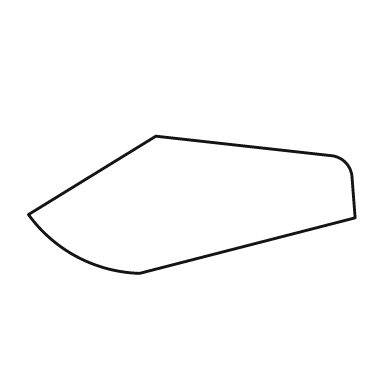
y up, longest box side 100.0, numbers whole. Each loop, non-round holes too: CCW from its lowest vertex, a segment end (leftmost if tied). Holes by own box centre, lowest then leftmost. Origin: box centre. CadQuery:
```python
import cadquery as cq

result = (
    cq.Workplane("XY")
    .moveTo(-16.0, -21.0)
    .lineTo(50.0, -4.0)
    .lineTo(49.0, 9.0)
    .threePointArc((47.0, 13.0), (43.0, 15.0))
    .lineTo(-11.0, 21.0)
    .lineTo(-50.0, -3.0)
    .threePointArc((-35.0, -16.0), (-16.0, -21.0))
    .close()
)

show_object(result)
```